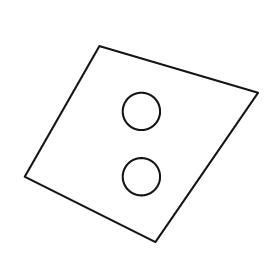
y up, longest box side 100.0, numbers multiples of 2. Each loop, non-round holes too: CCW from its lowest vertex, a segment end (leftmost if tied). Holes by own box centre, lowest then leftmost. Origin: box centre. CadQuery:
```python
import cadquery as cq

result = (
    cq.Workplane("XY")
    .moveTo(6.0, -42.0)
    .lineTo(50.0, 22.0)
    .lineTo(-18.0, 42.0)
    .lineTo(-50.0, -14.0)
    .close()
    .moveTo(0.0, -14.0)
    .circle(8.0)
    .moveTo(0.0, 14.0)
    .circle(8.0)
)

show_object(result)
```